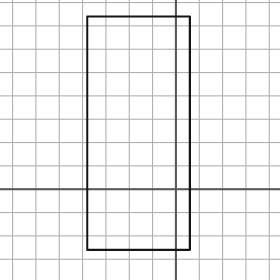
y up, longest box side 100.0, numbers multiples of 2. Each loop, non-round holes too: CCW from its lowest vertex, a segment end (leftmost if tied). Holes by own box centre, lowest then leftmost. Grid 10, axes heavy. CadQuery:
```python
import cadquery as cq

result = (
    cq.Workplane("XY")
    .moveTo(-38.0, -26.0)
    .lineTo(6.0, -26.0)
    .lineTo(6.0, 74.0)
    .lineTo(-38.0, 74.0)
    .close()
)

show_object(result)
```